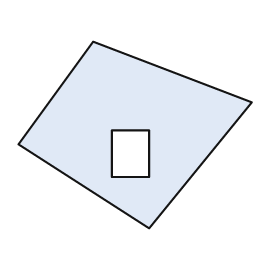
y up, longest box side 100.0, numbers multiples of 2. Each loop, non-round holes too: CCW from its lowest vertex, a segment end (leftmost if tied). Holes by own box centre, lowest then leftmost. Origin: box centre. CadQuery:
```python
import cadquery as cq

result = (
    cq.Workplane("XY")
    .moveTo(6.0, -40.0)
    .lineTo(50.0, 14.0)
    .lineTo(-18.0, 40.0)
    .lineTo(-50.0, -4.0)
    .close()
    .moveTo(-10.0, -18.0)
    .lineTo(6.0, -18.0)
    .lineTo(6.0, 2.0)
    .lineTo(-10.0, 2.0)
    .close()
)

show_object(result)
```